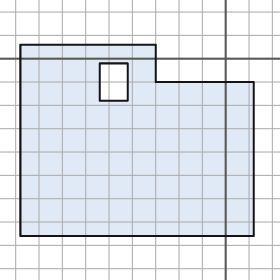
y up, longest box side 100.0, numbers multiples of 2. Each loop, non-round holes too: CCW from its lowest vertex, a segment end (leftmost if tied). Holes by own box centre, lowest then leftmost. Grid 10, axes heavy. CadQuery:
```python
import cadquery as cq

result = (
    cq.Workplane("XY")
    .moveTo(-88.0, -76.0)
    .lineTo(12.0, -76.0)
    .lineTo(12.0, -10.0)
    .lineTo(-30.0, -10.0)
    .lineTo(-30.0, 6.0)
    .lineTo(-88.0, 6.0)
    .close()
    .moveTo(-54.0, -18.0)
    .lineTo(-42.0, -18.0)
    .lineTo(-42.0, -2.0)
    .lineTo(-54.0, -2.0)
    .close()
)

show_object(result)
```